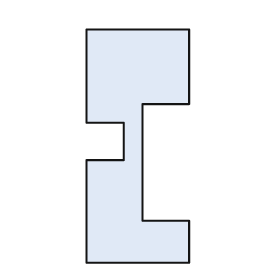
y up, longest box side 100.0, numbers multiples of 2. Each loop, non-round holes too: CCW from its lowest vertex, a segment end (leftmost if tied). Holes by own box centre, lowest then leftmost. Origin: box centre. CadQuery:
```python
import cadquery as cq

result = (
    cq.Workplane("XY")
    .moveTo(-22.0, -50.0)
    .lineTo(22.0, -50.0)
    .lineTo(22.0, -32.0)
    .lineTo(2.0, -32.0)
    .lineTo(2.0, 18.0)
    .lineTo(22.0, 18.0)
    .lineTo(22.0, 50.0)
    .lineTo(-22.0, 50.0)
    .lineTo(-22.0, 10.0)
    .lineTo(-6.0, 10.0)
    .lineTo(-6.0, -6.0)
    .lineTo(-22.0, -6.0)
    .close()
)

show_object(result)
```